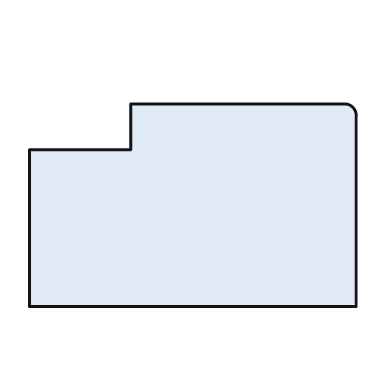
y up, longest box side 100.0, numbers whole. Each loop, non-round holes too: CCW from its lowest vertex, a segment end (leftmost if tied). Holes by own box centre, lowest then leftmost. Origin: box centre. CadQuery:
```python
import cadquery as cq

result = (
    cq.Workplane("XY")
    .moveTo(-50.0, -31.0)
    .lineTo(50.0, -31.0)
    .lineTo(50.0, 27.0)
    .threePointArc((49.0, 30.0), (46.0, 31.0))
    .lineTo(-19.0, 31.0)
    .lineTo(-19.0, 17.0)
    .lineTo(-50.0, 17.0)
    .close()
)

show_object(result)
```